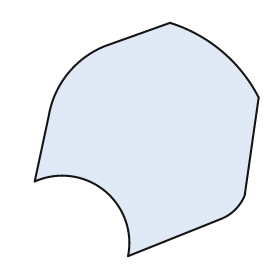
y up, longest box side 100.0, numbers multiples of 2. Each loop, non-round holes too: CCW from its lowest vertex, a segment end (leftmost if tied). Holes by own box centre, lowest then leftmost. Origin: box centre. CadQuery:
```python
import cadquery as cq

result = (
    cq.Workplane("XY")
    .moveTo(-8.0, -50.0)
    .lineTo(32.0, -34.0)
    .threePointArc((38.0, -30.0), (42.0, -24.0))
    .lineTo(48.0, 18.0)
    .threePointArc((32.0, 38.0), (10.0, 50.0))
    .lineTo(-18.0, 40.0)
    .threePointArc((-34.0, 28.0), (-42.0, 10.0))
    .lineTo(-48.0, -18.0)
    .threePointArc((-18.0, -22.0), (-8.0, -50.0))
    .close()
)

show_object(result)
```